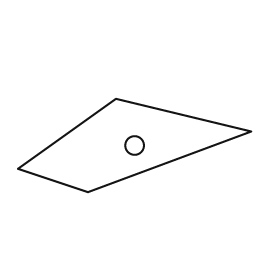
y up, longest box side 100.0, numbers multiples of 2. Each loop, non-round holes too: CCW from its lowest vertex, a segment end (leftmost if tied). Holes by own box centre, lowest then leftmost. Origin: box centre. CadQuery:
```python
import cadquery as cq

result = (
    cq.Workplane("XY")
    .moveTo(-20.0, -20.0)
    .lineTo(50.0, 6.0)
    .lineTo(-8.0, 20.0)
    .lineTo(-50.0, -10.0)
    .close()
    .moveTo(0.0, 0.0)
    .circle(4.0)
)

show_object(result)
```